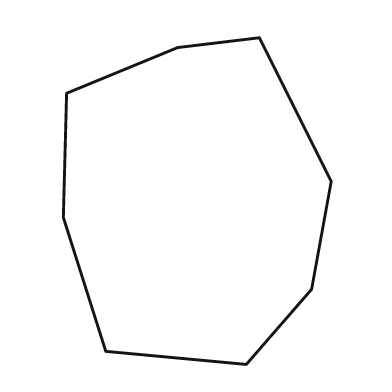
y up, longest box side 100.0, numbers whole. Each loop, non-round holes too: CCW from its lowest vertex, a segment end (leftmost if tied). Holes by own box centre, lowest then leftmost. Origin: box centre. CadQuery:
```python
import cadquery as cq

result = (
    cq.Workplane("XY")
    .moveTo(15.0, -50.0)
    .lineTo(35.0, -27.0)
    .lineTo(41.0, 6.0)
    .lineTo(19.0, 50.0)
    .lineTo(-6.0, 47.0)
    .lineTo(-40.0, 33.0)
    .lineTo(-41.0, -5.0)
    .lineTo(-28.0, -46.0)
    .close()
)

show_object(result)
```